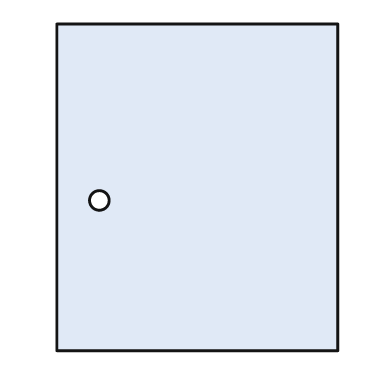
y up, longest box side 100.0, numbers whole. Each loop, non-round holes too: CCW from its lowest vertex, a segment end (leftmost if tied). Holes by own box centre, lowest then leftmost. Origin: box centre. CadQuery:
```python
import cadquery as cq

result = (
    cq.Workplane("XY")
    .moveTo(-43.0, -50.0)
    .lineTo(43.0, -50.0)
    .lineTo(43.0, 50.0)
    .lineTo(-43.0, 50.0)
    .close()
    .moveTo(-30.0, -4.0)
    .circle(3.0)
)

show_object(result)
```